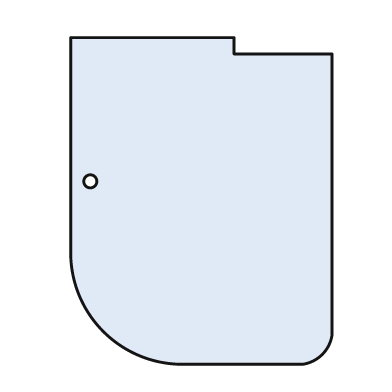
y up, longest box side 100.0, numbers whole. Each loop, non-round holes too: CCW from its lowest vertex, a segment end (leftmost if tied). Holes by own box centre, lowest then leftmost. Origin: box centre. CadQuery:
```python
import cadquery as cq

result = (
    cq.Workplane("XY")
    .moveTo(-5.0, -50.0)
    .lineTo(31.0, -50.0)
    .threePointArc((37.0, -47.0), (40.0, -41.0))
    .lineTo(40.0, 45.0)
    .lineTo(10.0, 45.0)
    .lineTo(10.0, 50.0)
    .lineTo(-40.0, 50.0)
    .lineTo(-40.0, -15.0)
    .threePointArc((-30.0, -40.0), (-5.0, -50.0))
    .close()
    .moveTo(-34.0, 6.0)
    .circle(2.0)
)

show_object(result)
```